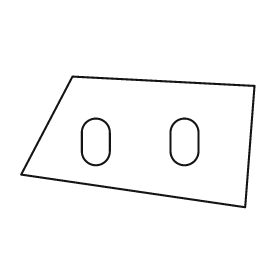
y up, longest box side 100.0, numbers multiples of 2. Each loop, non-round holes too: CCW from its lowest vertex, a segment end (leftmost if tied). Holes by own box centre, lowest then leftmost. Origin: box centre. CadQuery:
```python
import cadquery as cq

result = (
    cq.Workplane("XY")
    .moveTo(46.0, -28.0)
    .lineTo(50.0, 24.0)
    .lineTo(-28.0, 28.0)
    .lineTo(-50.0, -14.0)
    .close()
    .moveTo(-24.0, -4.0)
    .threePointArc((-18.0, -10.0), (-12.0, -4.0))
    .lineTo(-12.0, 4.0)
    .threePointArc((-18.0, 10.0), (-24.0, 4.0))
    .close()
    .moveTo(14.0, -4.0)
    .threePointArc((20.0, -10.0), (26.0, -4.0))
    .lineTo(26.0, 4.0)
    .threePointArc((20.0, 10.0), (14.0, 4.0))
    .close()
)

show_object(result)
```